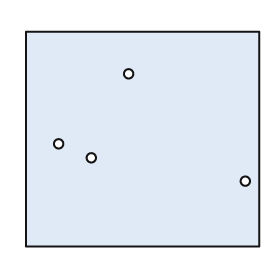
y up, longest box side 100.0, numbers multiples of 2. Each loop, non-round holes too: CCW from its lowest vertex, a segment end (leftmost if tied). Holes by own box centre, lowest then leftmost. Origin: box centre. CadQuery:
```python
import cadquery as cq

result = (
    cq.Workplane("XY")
    .moveTo(-50.0, -46.0)
    .lineTo(50.0, -46.0)
    .lineTo(50.0, 46.0)
    .lineTo(-50.0, 46.0)
    .close()
    .moveTo(44.0, -18.0)
    .circle(2.0)
    .moveTo(-22.0, -8.0)
    .circle(2.0)
    .moveTo(-36.0, -2.0)
    .circle(2.0)
    .moveTo(-6.0, 28.0)
    .circle(2.0)
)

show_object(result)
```